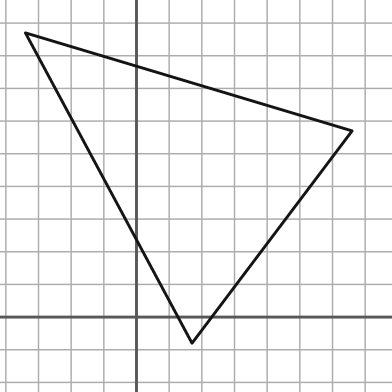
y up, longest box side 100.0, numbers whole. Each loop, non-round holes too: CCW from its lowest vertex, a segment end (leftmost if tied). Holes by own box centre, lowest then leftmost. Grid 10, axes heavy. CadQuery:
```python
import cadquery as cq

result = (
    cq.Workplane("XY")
    .moveTo(17.0, -8.0)
    .lineTo(66.0, 57.0)
    .lineTo(-34.0, 87.0)
    .close()
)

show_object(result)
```